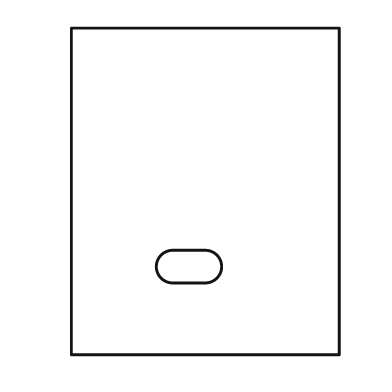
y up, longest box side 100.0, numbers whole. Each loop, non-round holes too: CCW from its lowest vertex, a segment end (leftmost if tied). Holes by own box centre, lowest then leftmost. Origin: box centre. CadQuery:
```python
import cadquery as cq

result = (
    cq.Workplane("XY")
    .moveTo(-41.0, -50.0)
    .lineTo(41.0, -50.0)
    .lineTo(41.0, 50.0)
    .lineTo(-41.0, 50.0)
    .close()
    .moveTo(-10.0, -28.0)
    .lineTo(0.0, -28.0)
    .threePointArc((5.0, -23.0), (0.0, -18.0))
    .lineTo(-10.0, -18.0)
    .threePointArc((-15.0, -23.0), (-10.0, -28.0))
    .close()
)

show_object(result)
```